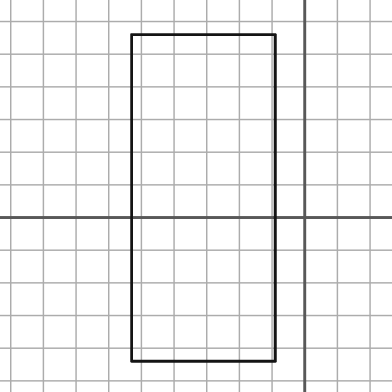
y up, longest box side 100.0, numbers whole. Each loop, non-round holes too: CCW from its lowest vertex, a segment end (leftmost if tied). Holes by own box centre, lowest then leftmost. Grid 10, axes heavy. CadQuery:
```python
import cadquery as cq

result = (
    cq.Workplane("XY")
    .moveTo(-53.0, -44.0)
    .lineTo(-9.0, -44.0)
    .lineTo(-9.0, 56.0)
    .lineTo(-53.0, 56.0)
    .close()
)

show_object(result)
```